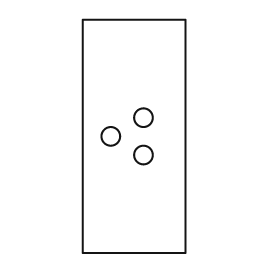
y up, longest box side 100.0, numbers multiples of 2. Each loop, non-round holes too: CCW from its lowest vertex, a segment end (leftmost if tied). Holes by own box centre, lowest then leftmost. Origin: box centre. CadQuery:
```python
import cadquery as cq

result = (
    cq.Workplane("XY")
    .moveTo(-22.0, -50.0)
    .lineTo(22.0, -50.0)
    .lineTo(22.0, 50.0)
    .lineTo(-22.0, 50.0)
    .close()
    .moveTo(4.0, -8.0)
    .circle(4.0)
    .moveTo(-10.0, 0.0)
    .circle(4.0)
    .moveTo(4.0, 8.0)
    .circle(4.0)
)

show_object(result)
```